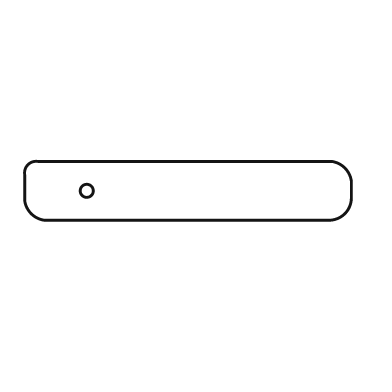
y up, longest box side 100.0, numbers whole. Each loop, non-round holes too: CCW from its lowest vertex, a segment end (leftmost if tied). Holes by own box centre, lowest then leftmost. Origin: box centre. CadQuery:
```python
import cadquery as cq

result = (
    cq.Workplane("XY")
    .moveTo(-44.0, -9.0)
    .lineTo(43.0, -9.0)
    .threePointArc((48.0, -7.0), (50.0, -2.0))
    .lineTo(50.0, 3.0)
    .threePointArc((48.0, 7.0), (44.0, 9.0))
    .lineTo(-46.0, 9.0)
    .threePointArc((-49.0, 8.0), (-50.0, 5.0))
    .lineTo(-50.0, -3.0)
    .threePointArc((-48.0, -7.0), (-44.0, -9.0))
    .close()
    .moveTo(-31.0, 0.0)
    .circle(2.0)
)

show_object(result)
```